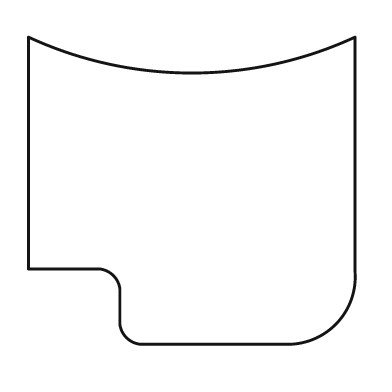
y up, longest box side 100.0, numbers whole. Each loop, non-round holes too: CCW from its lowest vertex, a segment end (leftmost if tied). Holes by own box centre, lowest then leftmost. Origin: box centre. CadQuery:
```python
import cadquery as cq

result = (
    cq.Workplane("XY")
    .moveTo(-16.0, -47.0)
    .lineTo(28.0, -47.0)
    .threePointArc((44.0, -41.0), (50.0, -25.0))
    .lineTo(50.0, 47.0)
    .threePointArc((0.0, 36.0), (-50.0, 47.0))
    .lineTo(-50.0, -24.0)
    .lineTo(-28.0, -24.0)
    .threePointArc((-24.0, -26.0), (-22.0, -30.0))
    .lineTo(-22.0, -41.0)
    .threePointArc((-20.0, -45.0), (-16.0, -47.0))
    .close()
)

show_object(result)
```